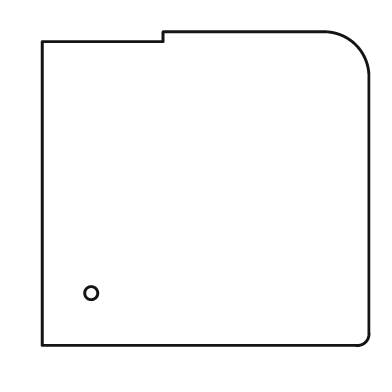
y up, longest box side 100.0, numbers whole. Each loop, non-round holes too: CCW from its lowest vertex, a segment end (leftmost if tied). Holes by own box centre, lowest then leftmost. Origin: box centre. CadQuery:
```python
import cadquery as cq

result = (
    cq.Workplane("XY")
    .moveTo(-50.0, -48.0)
    .lineTo(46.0, -48.0)
    .threePointArc((49.0, -47.0), (50.0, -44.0))
    .lineTo(50.0, 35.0)
    .threePointArc((46.0, 44.0), (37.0, 48.0))
    .lineTo(-13.0, 48.0)
    .lineTo(-13.0, 45.0)
    .lineTo(-50.0, 45.0)
    .close()
    .moveTo(-35.0, -32.0)
    .circle(2.0)
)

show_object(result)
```